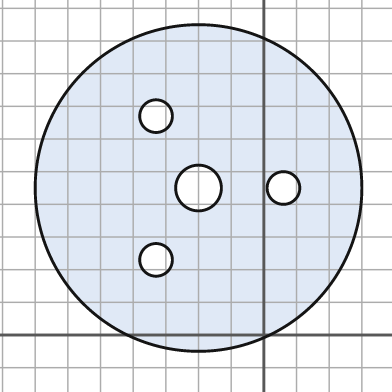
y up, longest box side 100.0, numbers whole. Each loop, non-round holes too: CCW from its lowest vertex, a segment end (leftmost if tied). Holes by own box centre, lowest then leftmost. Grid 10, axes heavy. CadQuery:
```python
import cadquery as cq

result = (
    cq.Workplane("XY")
    .moveTo(-20.0, 45.0)
    .circle(50.0)
    .moveTo(-33.0, 23.0)
    .circle(5.0)
    .moveTo(-20.0, 45.0)
    .circle(7.0)
    .moveTo(6.0, 45.0)
    .circle(5.0)
    .moveTo(-33.0, 67.0)
    .circle(5.0)
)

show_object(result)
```